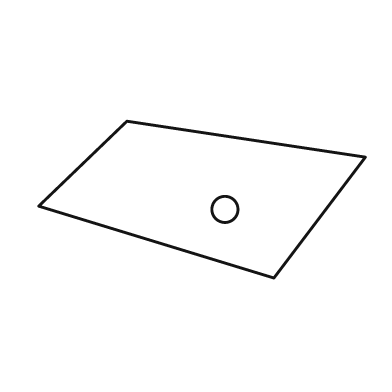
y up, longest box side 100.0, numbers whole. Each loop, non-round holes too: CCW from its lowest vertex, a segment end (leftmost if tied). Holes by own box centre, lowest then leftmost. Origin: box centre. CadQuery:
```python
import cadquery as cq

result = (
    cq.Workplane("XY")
    .moveTo(22.0, -24.0)
    .lineTo(50.0, 13.0)
    .lineTo(-23.0, 24.0)
    .lineTo(-50.0, -2.0)
    .close()
    .moveTo(7.0, -3.0)
    .circle(4.0)
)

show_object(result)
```